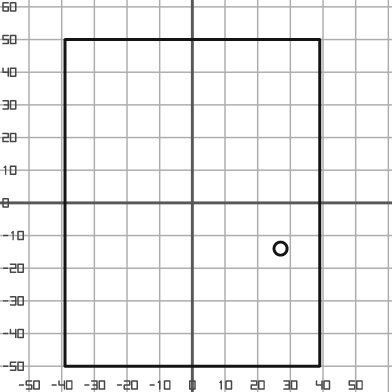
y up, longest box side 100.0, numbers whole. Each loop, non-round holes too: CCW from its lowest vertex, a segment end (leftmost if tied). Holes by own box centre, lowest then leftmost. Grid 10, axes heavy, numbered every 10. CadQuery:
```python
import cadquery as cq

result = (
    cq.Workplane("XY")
    .moveTo(-39.0, -50.0)
    .lineTo(39.0, -50.0)
    .lineTo(39.0, 50.0)
    .lineTo(-39.0, 50.0)
    .close()
    .moveTo(27.0, -14.0)
    .circle(2.0)
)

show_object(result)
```